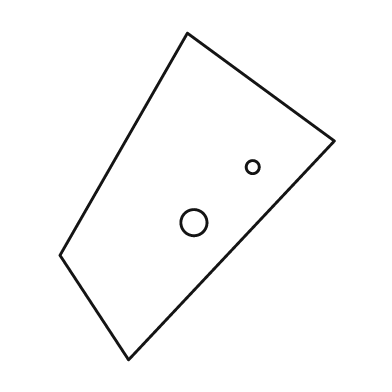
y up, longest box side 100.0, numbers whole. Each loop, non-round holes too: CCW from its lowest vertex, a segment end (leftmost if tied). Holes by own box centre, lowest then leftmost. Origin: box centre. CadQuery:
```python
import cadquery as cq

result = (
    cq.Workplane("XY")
    .moveTo(-21.0, -50.0)
    .lineTo(42.0, 17.0)
    .lineTo(-3.0, 50.0)
    .lineTo(-42.0, -18.0)
    .close()
    .moveTo(-1.0, -8.0)
    .circle(4.0)
    .moveTo(17.0, 9.0)
    .circle(2.0)
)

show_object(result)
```